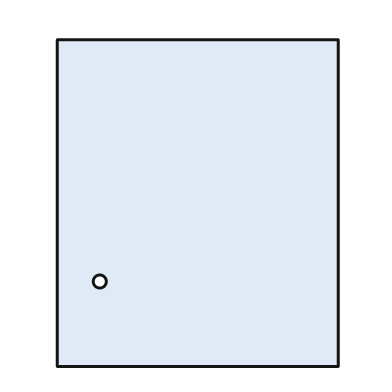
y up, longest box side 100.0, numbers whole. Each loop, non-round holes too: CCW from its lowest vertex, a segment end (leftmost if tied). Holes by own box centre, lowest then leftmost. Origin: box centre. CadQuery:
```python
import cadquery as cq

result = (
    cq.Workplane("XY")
    .moveTo(-43.0, -50.0)
    .lineTo(43.0, -50.0)
    .lineTo(43.0, 50.0)
    .lineTo(-43.0, 50.0)
    .close()
    .moveTo(-30.0, -24.0)
    .circle(2.0)
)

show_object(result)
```